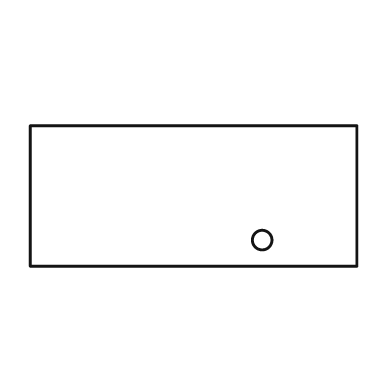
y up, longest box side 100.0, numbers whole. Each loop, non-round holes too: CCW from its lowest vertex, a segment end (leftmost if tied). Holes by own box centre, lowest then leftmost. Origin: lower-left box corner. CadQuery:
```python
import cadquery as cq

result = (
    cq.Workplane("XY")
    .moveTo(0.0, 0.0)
    .lineTo(100.0, 0.0)
    .lineTo(100.0, 43.0)
    .lineTo(0.0, 43.0)
    .close()
    .moveTo(71.0, 8.0)
    .circle(3.0)
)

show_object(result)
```